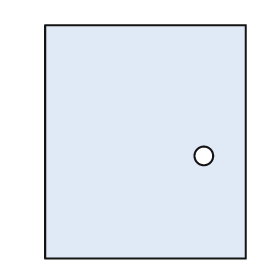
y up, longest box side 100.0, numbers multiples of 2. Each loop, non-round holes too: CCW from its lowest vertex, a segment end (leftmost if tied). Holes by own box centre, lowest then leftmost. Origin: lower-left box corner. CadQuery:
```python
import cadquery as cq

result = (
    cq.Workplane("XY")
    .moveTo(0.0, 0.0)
    .lineTo(86.0, 0.0)
    .lineTo(86.0, 100.0)
    .lineTo(0.0, 100.0)
    .close()
    .moveTo(68.0, 44.0)
    .circle(4.0)
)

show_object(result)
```